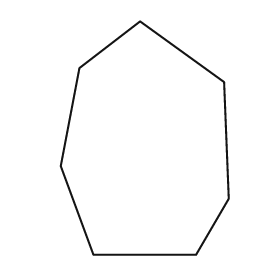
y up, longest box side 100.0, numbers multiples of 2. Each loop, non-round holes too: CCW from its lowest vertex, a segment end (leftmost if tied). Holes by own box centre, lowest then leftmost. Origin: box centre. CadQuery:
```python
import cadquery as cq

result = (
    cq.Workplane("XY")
    .moveTo(-22.0, -50.0)
    .lineTo(22.0, -50.0)
    .lineTo(36.0, -26.0)
    .lineTo(34.0, 24.0)
    .lineTo(-2.0, 50.0)
    .lineTo(-28.0, 30.0)
    .lineTo(-36.0, -12.0)
    .close()
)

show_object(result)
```